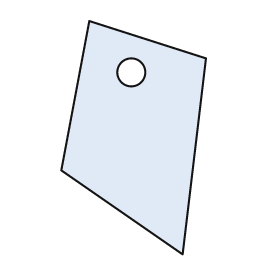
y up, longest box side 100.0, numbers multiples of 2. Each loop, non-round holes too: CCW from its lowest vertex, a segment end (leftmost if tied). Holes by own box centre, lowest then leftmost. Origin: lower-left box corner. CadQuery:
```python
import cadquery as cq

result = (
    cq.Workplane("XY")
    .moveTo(52.0, 0.0)
    .lineTo(62.0, 84.0)
    .lineTo(12.0, 100.0)
    .lineTo(0.0, 36.0)
    .close()
    .moveTo(30.0, 78.0)
    .circle(6.0)
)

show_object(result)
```